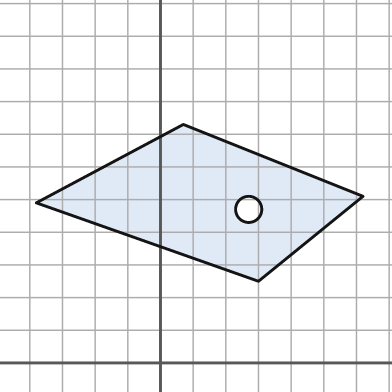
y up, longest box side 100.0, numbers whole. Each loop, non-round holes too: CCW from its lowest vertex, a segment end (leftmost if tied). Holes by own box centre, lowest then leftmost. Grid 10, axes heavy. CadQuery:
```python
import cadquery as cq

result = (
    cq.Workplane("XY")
    .moveTo(30.0, 25.0)
    .lineTo(62.0, 51.0)
    .lineTo(7.0, 73.0)
    .lineTo(-38.0, 49.0)
    .close()
    .moveTo(27.0, 47.0)
    .circle(4.0)
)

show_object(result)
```